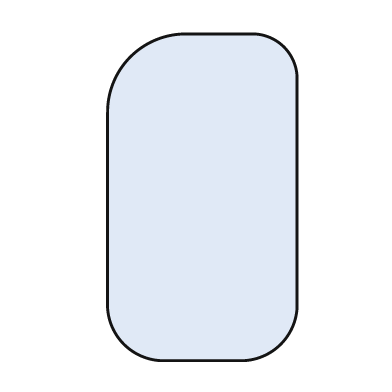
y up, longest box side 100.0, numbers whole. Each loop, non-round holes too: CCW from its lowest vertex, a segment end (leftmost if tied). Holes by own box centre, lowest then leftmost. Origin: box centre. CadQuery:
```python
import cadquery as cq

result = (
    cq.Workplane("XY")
    .moveTo(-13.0, -50.0)
    .lineTo(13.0, -50.0)
    .threePointArc((24.0, -45.0), (29.0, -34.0))
    .lineTo(29.0, 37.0)
    .threePointArc((25.0, 46.0), (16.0, 50.0))
    .lineTo(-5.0, 50.0)
    .threePointArc((-22.0, 43.0), (-29.0, 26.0))
    .lineTo(-29.0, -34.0)
    .threePointArc((-24.0, -45.0), (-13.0, -50.0))
    .close()
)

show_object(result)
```